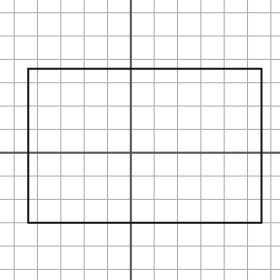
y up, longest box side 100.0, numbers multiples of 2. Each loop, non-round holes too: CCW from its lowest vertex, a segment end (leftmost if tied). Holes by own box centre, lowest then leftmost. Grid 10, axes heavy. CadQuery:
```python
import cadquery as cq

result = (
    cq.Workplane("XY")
    .moveTo(-44.0, -30.0)
    .lineTo(56.0, -30.0)
    .lineTo(56.0, 36.0)
    .lineTo(-44.0, 36.0)
    .close()
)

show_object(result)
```